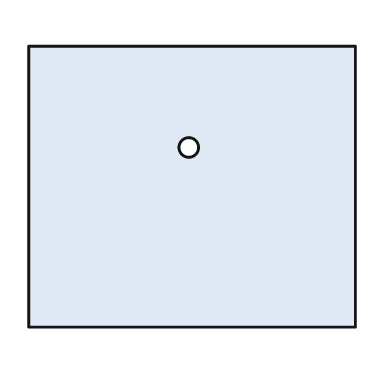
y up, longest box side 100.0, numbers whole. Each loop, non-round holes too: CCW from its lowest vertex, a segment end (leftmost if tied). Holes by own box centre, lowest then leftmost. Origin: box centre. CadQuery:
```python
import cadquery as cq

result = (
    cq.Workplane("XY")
    .moveTo(-50.0, -43.0)
    .lineTo(50.0, -43.0)
    .lineTo(50.0, 43.0)
    .lineTo(-50.0, 43.0)
    .close()
    .moveTo(-1.0, 12.0)
    .circle(3.0)
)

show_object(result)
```